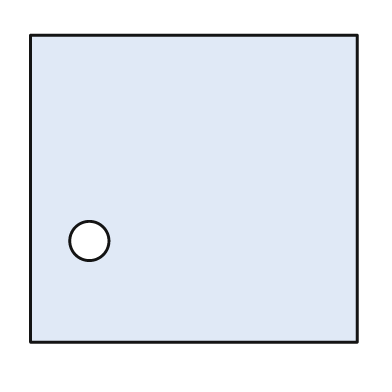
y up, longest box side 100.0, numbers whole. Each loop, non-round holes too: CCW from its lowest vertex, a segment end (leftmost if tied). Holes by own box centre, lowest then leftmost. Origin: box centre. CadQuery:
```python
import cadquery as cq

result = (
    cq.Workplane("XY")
    .moveTo(-50.0, -47.0)
    .lineTo(50.0, -47.0)
    .lineTo(50.0, 47.0)
    .lineTo(-50.0, 47.0)
    .close()
    .moveTo(-32.0, -16.0)
    .circle(6.0)
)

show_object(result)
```